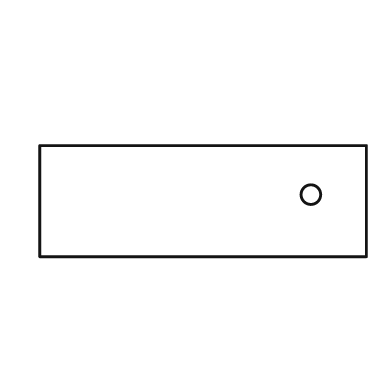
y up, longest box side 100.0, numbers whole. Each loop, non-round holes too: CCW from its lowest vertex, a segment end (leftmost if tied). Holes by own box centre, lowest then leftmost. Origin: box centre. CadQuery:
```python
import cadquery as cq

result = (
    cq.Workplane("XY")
    .moveTo(-50.0, -17.0)
    .lineTo(50.0, -17.0)
    .lineTo(50.0, 17.0)
    .lineTo(-50.0, 17.0)
    .close()
    .moveTo(33.0, 2.0)
    .circle(3.0)
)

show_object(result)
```